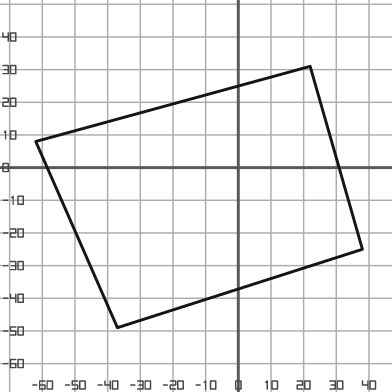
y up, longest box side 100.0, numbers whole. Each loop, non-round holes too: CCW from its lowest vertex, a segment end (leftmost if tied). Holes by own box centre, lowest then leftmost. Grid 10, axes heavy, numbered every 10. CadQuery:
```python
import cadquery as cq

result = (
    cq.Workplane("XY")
    .moveTo(-37.0, -49.0)
    .lineTo(38.0, -25.0)
    .lineTo(22.0, 31.0)
    .lineTo(-62.0, 8.0)
    .close()
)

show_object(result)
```